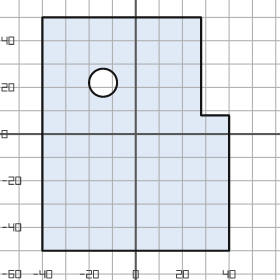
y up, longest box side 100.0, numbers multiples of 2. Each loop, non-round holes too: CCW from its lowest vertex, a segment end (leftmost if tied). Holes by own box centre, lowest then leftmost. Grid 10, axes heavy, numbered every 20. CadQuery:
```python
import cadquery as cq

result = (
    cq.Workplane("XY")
    .moveTo(-40.0, -50.0)
    .lineTo(40.0, -50.0)
    .lineTo(40.0, 8.0)
    .lineTo(28.0, 8.0)
    .lineTo(28.0, 50.0)
    .lineTo(-40.0, 50.0)
    .close()
    .moveTo(-14.0, 22.0)
    .circle(6.0)
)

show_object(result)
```